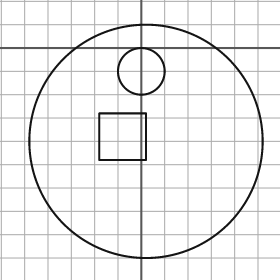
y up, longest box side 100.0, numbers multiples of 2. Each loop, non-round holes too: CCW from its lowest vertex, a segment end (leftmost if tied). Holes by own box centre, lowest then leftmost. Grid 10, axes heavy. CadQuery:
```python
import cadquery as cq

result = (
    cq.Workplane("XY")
    .moveTo(2.0, -40.0)
    .circle(50.0)
    .moveTo(-18.0, -48.0)
    .lineTo(2.0, -48.0)
    .lineTo(2.0, -28.0)
    .lineTo(-18.0, -28.0)
    .close()
    .moveTo(0.0, -10.0)
    .circle(10.0)
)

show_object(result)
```